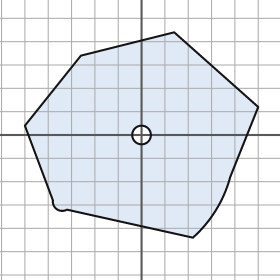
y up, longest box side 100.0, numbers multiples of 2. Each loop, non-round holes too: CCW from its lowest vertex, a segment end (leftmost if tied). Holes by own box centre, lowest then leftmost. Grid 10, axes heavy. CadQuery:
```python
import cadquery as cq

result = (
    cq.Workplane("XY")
    .moveTo(22.0, -44.0)
    .threePointArc((32.0, -32.0), (38.0, -18.0))
    .lineTo(50.0, 12.0)
    .lineTo(14.0, 44.0)
    .lineTo(-26.0, 34.0)
    .lineTo(-50.0, 4.0)
    .lineTo(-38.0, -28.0)
    .threePointArc((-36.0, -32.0), (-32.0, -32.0))
    .close()
    .moveTo(0.0, 0.0)
    .circle(4.0)
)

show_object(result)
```